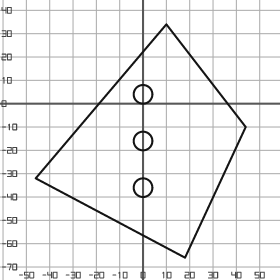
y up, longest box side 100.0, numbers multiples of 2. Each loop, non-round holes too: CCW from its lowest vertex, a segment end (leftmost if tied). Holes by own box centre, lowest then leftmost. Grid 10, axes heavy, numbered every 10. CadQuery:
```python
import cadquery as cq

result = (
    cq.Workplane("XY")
    .moveTo(18.0, -66.0)
    .lineTo(44.0, -10.0)
    .lineTo(10.0, 34.0)
    .lineTo(-46.0, -32.0)
    .close()
    .moveTo(0.0, -36.0)
    .circle(4.0)
    .moveTo(0.0, -16.0)
    .circle(4.0)
    .moveTo(0.0, 4.0)
    .circle(4.0)
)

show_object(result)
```